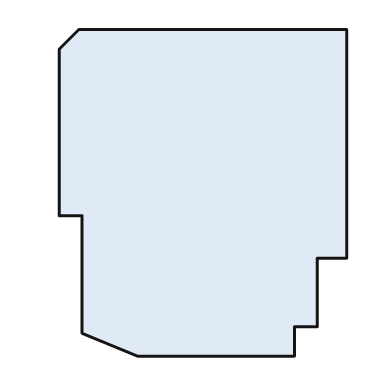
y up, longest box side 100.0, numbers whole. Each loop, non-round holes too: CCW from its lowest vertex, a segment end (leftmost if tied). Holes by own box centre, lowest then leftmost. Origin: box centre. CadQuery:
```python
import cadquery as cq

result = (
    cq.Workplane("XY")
    .moveTo(-20.0, -50.0)
    .lineTo(28.0, -50.0)
    .lineTo(28.0, -41.0)
    .lineTo(35.0, -41.0)
    .lineTo(35.0, -20.0)
    .lineTo(44.0, -20.0)
    .lineTo(44.0, 50.0)
    .lineTo(-38.0, 50.0)
    .lineTo(-44.0, 44.0)
    .lineTo(-44.0, -7.0)
    .lineTo(-37.0, -7.0)
    .lineTo(-37.0, -43.0)
    .close()
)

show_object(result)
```